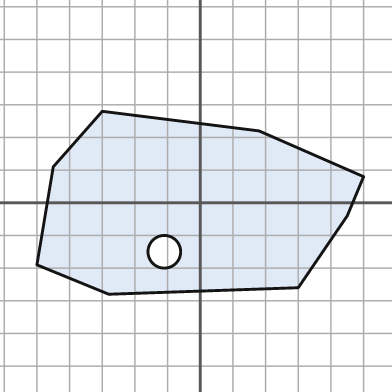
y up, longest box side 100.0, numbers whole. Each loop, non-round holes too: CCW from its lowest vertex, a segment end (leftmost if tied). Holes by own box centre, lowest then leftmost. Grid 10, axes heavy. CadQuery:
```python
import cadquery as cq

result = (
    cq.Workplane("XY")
    .moveTo(-28.0, -28.0)
    .lineTo(30.0, -26.0)
    .lineTo(45.0, -4.0)
    .lineTo(50.0, 8.0)
    .lineTo(18.0, 22.0)
    .lineTo(-30.0, 28.0)
    .lineTo(-45.0, 11.0)
    .lineTo(-50.0, -19.0)
    .close()
    .moveTo(-11.0, -15.0)
    .circle(5.0)
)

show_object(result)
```